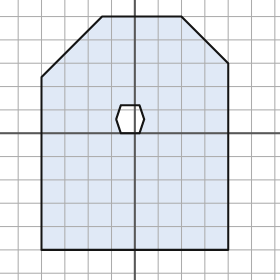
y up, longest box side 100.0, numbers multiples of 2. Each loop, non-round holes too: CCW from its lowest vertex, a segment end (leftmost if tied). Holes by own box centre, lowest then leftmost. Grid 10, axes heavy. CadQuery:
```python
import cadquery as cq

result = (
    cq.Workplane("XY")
    .moveTo(-40.0, -50.0)
    .lineTo(40.0, -50.0)
    .lineTo(40.0, 30.0)
    .lineTo(20.0, 50.0)
    .lineTo(-14.0, 50.0)
    .lineTo(-40.0, 24.0)
    .close()
    .moveTo(-6.0, 0.0)
    .lineTo(2.0, 0.0)
    .lineTo(4.0, 6.0)
    .lineTo(2.0, 12.0)
    .lineTo(-6.0, 12.0)
    .lineTo(-8.0, 6.0)
    .close()
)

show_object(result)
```